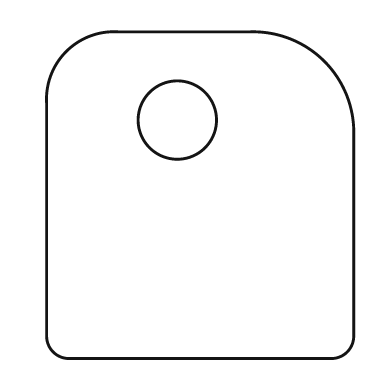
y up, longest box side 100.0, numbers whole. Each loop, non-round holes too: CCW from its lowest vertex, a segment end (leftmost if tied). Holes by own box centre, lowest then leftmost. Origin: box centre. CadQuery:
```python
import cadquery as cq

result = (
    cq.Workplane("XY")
    .moveTo(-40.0, -50.0)
    .lineTo(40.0, -50.0)
    .threePointArc((45.0, -48.0), (47.0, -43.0))
    .lineTo(47.0, 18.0)
    .threePointArc((38.0, 41.0), (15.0, 50.0))
    .lineTo(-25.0, 50.0)
    .threePointArc((-41.0, 44.0), (-47.0, 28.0))
    .lineTo(-47.0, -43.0)
    .threePointArc((-45.0, -48.0), (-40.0, -50.0))
    .close()
    .moveTo(-7.0, 23.0)
    .circle(12.0)
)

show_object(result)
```